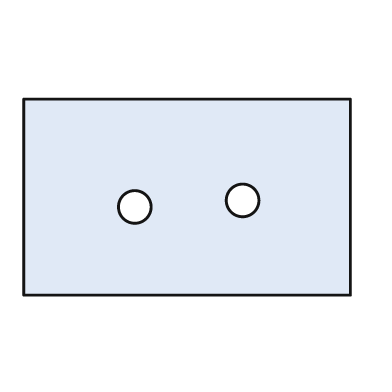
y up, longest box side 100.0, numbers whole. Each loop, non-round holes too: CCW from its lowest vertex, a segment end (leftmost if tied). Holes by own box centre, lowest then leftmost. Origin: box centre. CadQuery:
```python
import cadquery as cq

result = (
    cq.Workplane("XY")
    .moveTo(-50.0, -30.0)
    .lineTo(50.0, -30.0)
    .lineTo(50.0, 30.0)
    .lineTo(-50.0, 30.0)
    .close()
    .moveTo(-16.0, -3.0)
    .circle(5.0)
    .moveTo(17.0, -1.0)
    .circle(5.0)
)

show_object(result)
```